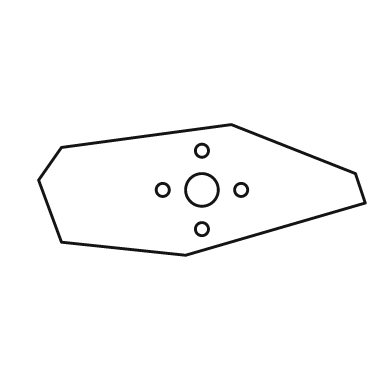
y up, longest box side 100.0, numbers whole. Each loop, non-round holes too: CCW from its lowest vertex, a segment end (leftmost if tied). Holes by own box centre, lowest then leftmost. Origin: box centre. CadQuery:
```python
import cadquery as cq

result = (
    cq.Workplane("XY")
    .moveTo(-5.0, -20.0)
    .lineTo(50.0, -4.0)
    .lineTo(47.0, 5.0)
    .lineTo(9.0, 20.0)
    .lineTo(-43.0, 13.0)
    .lineTo(-50.0, 3.0)
    .lineTo(-43.0, -16.0)
    .close()
    .moveTo(0.0, -12.0)
    .circle(2.0)
    .moveTo(-12.0, 0.0)
    .circle(2.0)
    .moveTo(0.0, 0.0)
    .circle(5.0)
    .moveTo(12.0, 0.0)
    .circle(2.0)
    .moveTo(0.0, 12.0)
    .circle(2.0)
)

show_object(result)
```